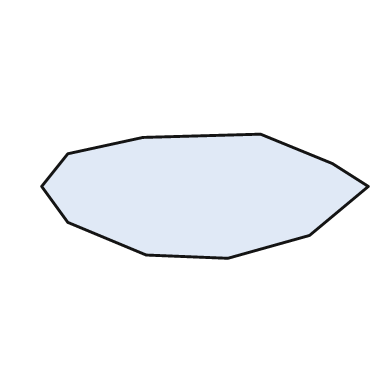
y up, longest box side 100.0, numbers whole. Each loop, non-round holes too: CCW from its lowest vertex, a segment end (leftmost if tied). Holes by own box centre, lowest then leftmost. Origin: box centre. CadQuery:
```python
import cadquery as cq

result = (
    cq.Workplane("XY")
    .moveTo(7.0, -19.0)
    .lineTo(32.0, -12.0)
    .lineTo(50.0, 3.0)
    .lineTo(39.0, 10.0)
    .lineTo(17.0, 19.0)
    .lineTo(-19.0, 18.0)
    .lineTo(-42.0, 13.0)
    .lineTo(-50.0, 3.0)
    .lineTo(-42.0, -8.0)
    .lineTo(-18.0, -18.0)
    .close()
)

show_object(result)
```